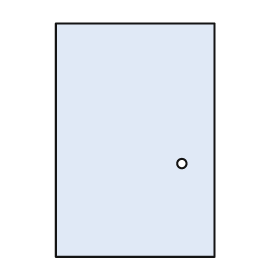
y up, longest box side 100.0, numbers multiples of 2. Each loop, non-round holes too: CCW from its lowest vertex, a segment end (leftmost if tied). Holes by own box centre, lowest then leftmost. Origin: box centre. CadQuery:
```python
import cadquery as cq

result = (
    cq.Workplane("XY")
    .moveTo(-34.0, -50.0)
    .lineTo(34.0, -50.0)
    .lineTo(34.0, 50.0)
    .lineTo(-34.0, 50.0)
    .close()
    .moveTo(20.0, -10.0)
    .circle(2.0)
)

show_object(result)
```